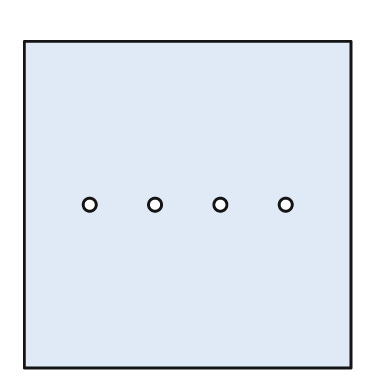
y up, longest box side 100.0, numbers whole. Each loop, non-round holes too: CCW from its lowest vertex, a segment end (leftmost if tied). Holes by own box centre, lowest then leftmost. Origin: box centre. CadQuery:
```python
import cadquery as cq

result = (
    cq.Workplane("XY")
    .moveTo(-50.0, -50.0)
    .lineTo(50.0, -50.0)
    .lineTo(50.0, 50.0)
    .lineTo(-50.0, 50.0)
    .close()
    .moveTo(-30.0, 0.0)
    .circle(2.0)
    .moveTo(-10.0, 0.0)
    .circle(2.0)
    .moveTo(10.0, 0.0)
    .circle(2.0)
    .moveTo(30.0, 0.0)
    .circle(2.0)
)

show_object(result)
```